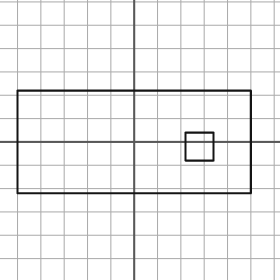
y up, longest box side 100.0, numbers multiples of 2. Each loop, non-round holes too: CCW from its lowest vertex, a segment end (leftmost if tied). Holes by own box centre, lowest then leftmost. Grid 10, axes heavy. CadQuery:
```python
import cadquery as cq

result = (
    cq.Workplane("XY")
    .moveTo(-50.0, -22.0)
    .lineTo(50.0, -22.0)
    .lineTo(50.0, 22.0)
    .lineTo(-50.0, 22.0)
    .close()
    .moveTo(22.0, -8.0)
    .lineTo(34.0, -8.0)
    .lineTo(34.0, 4.0)
    .lineTo(22.0, 4.0)
    .close()
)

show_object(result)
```